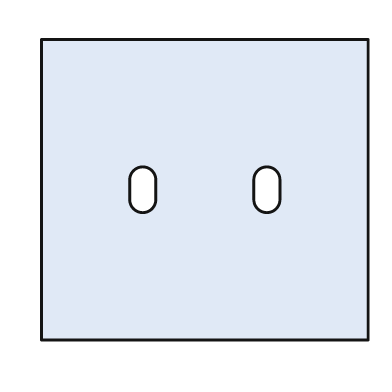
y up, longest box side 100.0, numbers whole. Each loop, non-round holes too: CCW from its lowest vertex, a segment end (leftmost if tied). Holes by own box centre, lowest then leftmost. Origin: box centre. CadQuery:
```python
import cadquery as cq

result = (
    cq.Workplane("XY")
    .moveTo(-50.0, -46.0)
    .lineTo(50.0, -46.0)
    .lineTo(50.0, 46.0)
    .lineTo(-50.0, 46.0)
    .close()
    .moveTo(-23.0, -3.0)
    .threePointArc((-19.0, -7.0), (-15.0, -3.0))
    .lineTo(-15.0, 3.0)
    .threePointArc((-19.0, 7.0), (-23.0, 3.0))
    .close()
    .moveTo(15.0, -3.0)
    .threePointArc((19.0, -7.0), (23.0, -3.0))
    .lineTo(23.0, 3.0)
    .threePointArc((19.0, 7.0), (15.0, 3.0))
    .close()
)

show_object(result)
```